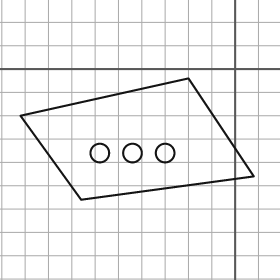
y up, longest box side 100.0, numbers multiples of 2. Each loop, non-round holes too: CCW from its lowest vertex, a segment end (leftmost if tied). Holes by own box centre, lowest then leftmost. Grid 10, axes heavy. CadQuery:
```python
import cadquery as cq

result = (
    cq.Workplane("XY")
    .moveTo(-66.0, -56.0)
    .lineTo(8.0, -46.0)
    .lineTo(-20.0, -4.0)
    .lineTo(-92.0, -20.0)
    .close()
    .moveTo(-58.0, -36.0)
    .circle(4.0)
    .moveTo(-44.0, -36.0)
    .circle(4.0)
    .moveTo(-30.0, -36.0)
    .circle(4.0)
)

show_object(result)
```